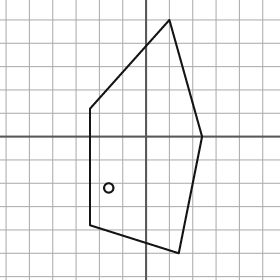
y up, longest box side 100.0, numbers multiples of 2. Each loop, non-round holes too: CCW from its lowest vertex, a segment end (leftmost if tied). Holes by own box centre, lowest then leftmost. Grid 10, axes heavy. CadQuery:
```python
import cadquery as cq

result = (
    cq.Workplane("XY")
    .moveTo(14.0, -50.0)
    .lineTo(24.0, 0.0)
    .lineTo(10.0, 50.0)
    .lineTo(-24.0, 12.0)
    .lineTo(-24.0, -38.0)
    .close()
    .moveTo(-16.0, -22.0)
    .circle(2.0)
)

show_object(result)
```